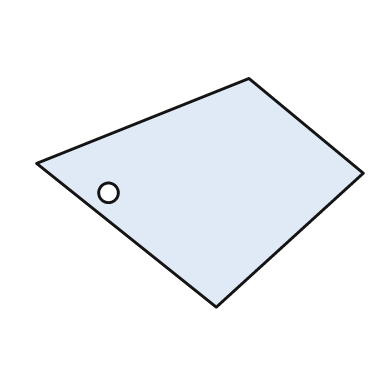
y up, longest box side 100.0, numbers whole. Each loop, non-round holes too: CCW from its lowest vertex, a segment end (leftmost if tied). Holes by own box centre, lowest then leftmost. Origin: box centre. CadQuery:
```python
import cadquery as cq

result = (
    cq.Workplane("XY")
    .moveTo(5.0, -35.0)
    .lineTo(50.0, 6.0)
    .lineTo(15.0, 35.0)
    .lineTo(-50.0, 9.0)
    .close()
    .moveTo(-28.0, 0.0)
    .circle(3.0)
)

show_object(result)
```